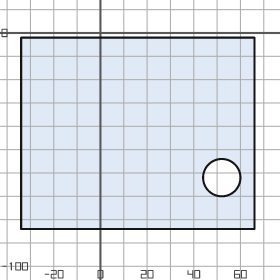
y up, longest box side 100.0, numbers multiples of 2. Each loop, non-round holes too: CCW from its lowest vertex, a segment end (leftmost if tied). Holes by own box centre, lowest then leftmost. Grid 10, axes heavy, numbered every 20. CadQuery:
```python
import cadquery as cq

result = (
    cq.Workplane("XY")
    .moveTo(-34.0, -84.0)
    .lineTo(66.0, -84.0)
    .lineTo(66.0, -2.0)
    .lineTo(-34.0, -2.0)
    .close()
    .moveTo(52.0, -62.0)
    .circle(8.0)
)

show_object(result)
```